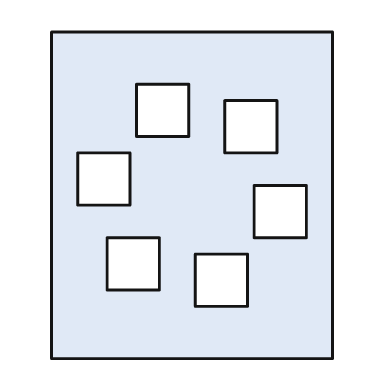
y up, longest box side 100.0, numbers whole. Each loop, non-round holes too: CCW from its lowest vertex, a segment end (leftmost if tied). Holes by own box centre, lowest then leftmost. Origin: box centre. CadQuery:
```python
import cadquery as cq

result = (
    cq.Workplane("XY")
    .moveTo(-43.0, -50.0)
    .lineTo(43.0, -50.0)
    .lineTo(43.0, 50.0)
    .lineTo(-43.0, 50.0)
    .close()
    .moveTo(1.0, -34.0)
    .lineTo(17.0, -34.0)
    .lineTo(17.0, -18.0)
    .lineTo(1.0, -18.0)
    .close()
    .moveTo(-26.0, -29.0)
    .lineTo(-10.0, -29.0)
    .lineTo(-10.0, -13.0)
    .lineTo(-26.0, -13.0)
    .close()
    .moveTo(19.0, -13.0)
    .lineTo(35.0, -13.0)
    .lineTo(35.0, 3.0)
    .lineTo(19.0, 3.0)
    .close()
    .moveTo(-35.0, -3.0)
    .lineTo(-19.0, -3.0)
    .lineTo(-19.0, 13.0)
    .lineTo(-35.0, 13.0)
    .close()
    .moveTo(10.0, 13.0)
    .lineTo(26.0, 13.0)
    .lineTo(26.0, 29.0)
    .lineTo(10.0, 29.0)
    .close()
    .moveTo(-17.0, 18.0)
    .lineTo(-1.0, 18.0)
    .lineTo(-1.0, 34.0)
    .lineTo(-17.0, 34.0)
    .close()
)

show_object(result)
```